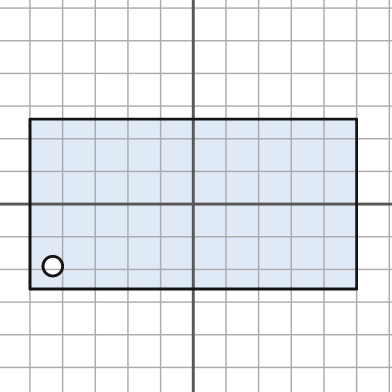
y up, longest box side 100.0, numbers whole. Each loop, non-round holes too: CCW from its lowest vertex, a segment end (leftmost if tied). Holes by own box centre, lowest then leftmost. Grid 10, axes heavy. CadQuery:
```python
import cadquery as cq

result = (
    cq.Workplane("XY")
    .moveTo(-50.0, -26.0)
    .lineTo(50.0, -26.0)
    .lineTo(50.0, 26.0)
    .lineTo(-50.0, 26.0)
    .close()
    .moveTo(-43.0, -19.0)
    .circle(3.0)
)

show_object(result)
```